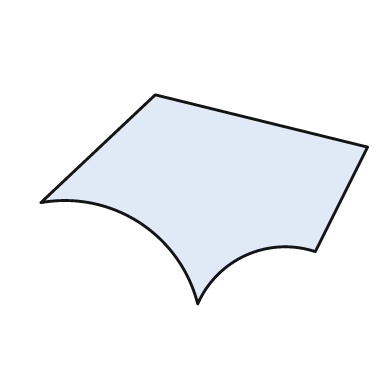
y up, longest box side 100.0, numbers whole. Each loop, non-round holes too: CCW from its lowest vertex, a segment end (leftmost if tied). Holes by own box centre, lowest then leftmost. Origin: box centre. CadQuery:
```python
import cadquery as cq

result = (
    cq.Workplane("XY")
    .moveTo(-2.0, -32.0)
    .threePointArc((13.0, -17.0), (34.0, -16.0))
    .lineTo(50.0, 16.0)
    .lineTo(-15.0, 32.0)
    .lineTo(-50.0, -1.0)
    .threePointArc((-20.0, -7.0), (-2.0, -32.0))
    .close()
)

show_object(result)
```